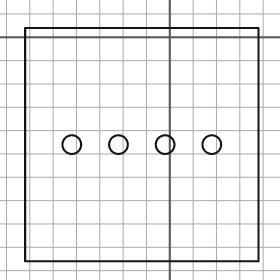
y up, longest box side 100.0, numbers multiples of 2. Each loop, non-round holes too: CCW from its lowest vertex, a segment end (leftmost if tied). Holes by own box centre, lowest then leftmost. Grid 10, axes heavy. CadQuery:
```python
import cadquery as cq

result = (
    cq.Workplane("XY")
    .moveTo(-62.0, -96.0)
    .lineTo(38.0, -96.0)
    .lineTo(38.0, 4.0)
    .lineTo(-62.0, 4.0)
    .close()
    .moveTo(-42.0, -46.0)
    .circle(4.0)
    .moveTo(-22.0, -46.0)
    .circle(4.0)
    .moveTo(-2.0, -46.0)
    .circle(4.0)
    .moveTo(18.0, -46.0)
    .circle(4.0)
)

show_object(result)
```